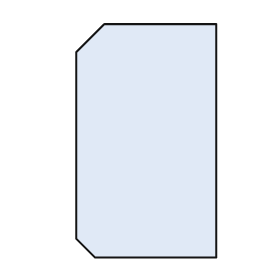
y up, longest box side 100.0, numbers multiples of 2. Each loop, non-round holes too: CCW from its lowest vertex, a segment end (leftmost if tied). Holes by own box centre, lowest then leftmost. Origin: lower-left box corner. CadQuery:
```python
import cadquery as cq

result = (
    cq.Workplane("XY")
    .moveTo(8.0, 0.0)
    .lineTo(60.0, 0.0)
    .lineTo(60.0, 100.0)
    .lineTo(12.0, 100.0)
    .lineTo(0.0, 88.0)
    .lineTo(0.0, 8.0)
    .close()
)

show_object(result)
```